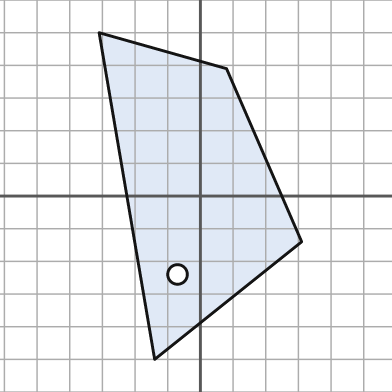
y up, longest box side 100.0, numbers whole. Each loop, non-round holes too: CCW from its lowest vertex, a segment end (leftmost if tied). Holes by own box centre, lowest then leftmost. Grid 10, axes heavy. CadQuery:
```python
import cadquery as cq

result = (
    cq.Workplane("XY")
    .moveTo(-14.0, -50.0)
    .lineTo(31.0, -14.0)
    .lineTo(8.0, 39.0)
    .lineTo(-31.0, 50.0)
    .close()
    .moveTo(-7.0, -24.0)
    .circle(3.0)
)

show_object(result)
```